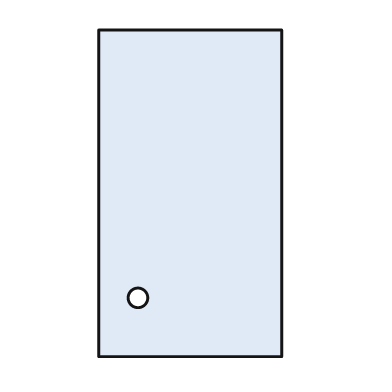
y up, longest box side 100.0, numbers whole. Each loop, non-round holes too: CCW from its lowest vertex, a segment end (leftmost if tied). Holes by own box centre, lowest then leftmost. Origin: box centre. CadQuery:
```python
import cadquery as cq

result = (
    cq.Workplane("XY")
    .moveTo(-28.0, -50.0)
    .lineTo(28.0, -50.0)
    .lineTo(28.0, 50.0)
    .lineTo(-28.0, 50.0)
    .close()
    .moveTo(-16.0, -32.0)
    .circle(3.0)
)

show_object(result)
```